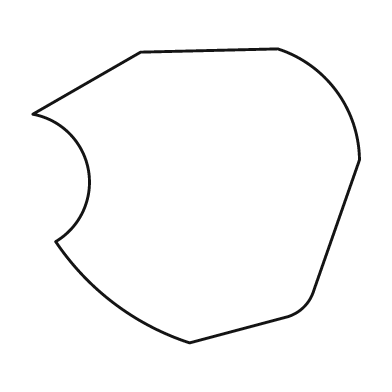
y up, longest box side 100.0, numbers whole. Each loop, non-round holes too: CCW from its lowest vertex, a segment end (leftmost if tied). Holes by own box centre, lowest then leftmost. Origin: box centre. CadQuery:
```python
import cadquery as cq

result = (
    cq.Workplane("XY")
    .moveTo(-2.0, -45.0)
    .lineTo(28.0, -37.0)
    .threePointArc((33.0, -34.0), (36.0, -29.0))
    .lineTo(50.0, 11.0)
    .threePointArc((43.0, 32.0), (25.0, 45.0))
    .lineTo(-17.0, 44.0)
    .lineTo(-50.0, 25.0)
    .threePointArc((-33.0, 8.0), (-43.0, -14.0))
    .threePointArc((-25.0, -33.0), (-2.0, -45.0))
    .close()
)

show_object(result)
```